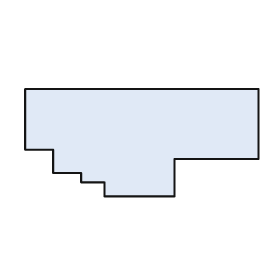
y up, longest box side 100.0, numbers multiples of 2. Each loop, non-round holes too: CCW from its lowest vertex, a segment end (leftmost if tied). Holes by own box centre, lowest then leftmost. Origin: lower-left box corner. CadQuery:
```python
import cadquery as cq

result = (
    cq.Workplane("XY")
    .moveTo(34.0, 0.0)
    .lineTo(64.0, 0.0)
    .lineTo(64.0, 16.0)
    .lineTo(100.0, 16.0)
    .lineTo(100.0, 46.0)
    .lineTo(0.0, 46.0)
    .lineTo(0.0, 20.0)
    .lineTo(12.0, 20.0)
    .lineTo(12.0, 10.0)
    .lineTo(24.0, 10.0)
    .lineTo(24.0, 6.0)
    .lineTo(34.0, 6.0)
    .close()
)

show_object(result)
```